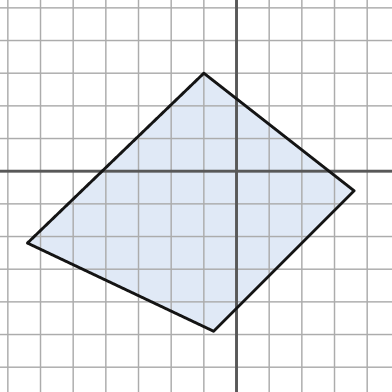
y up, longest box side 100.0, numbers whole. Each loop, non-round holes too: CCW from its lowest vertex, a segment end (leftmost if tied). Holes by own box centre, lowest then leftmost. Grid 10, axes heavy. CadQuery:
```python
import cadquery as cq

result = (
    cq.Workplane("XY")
    .moveTo(-7.0, -49.0)
    .lineTo(36.0, -6.0)
    .lineTo(-10.0, 30.0)
    .lineTo(-64.0, -22.0)
    .close()
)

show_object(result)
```